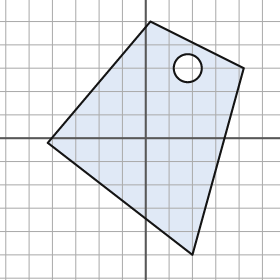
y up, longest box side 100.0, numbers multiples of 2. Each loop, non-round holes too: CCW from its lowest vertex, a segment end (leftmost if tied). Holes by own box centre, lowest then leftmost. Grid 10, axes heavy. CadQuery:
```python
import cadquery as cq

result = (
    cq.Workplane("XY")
    .moveTo(20.0, -50.0)
    .lineTo(42.0, 30.0)
    .lineTo(2.0, 50.0)
    .lineTo(-42.0, -2.0)
    .close()
    .moveTo(18.0, 30.0)
    .circle(6.0)
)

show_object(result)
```